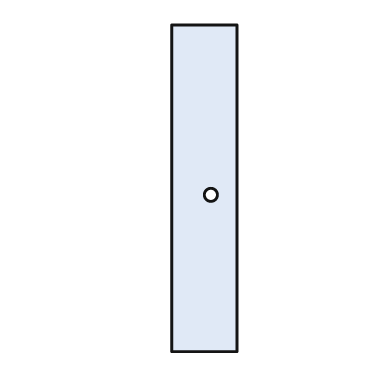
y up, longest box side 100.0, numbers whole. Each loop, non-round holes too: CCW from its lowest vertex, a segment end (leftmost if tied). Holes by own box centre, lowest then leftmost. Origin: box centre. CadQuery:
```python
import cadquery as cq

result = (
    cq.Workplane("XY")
    .moveTo(-10.0, -50.0)
    .lineTo(10.0, -50.0)
    .lineTo(10.0, 50.0)
    .lineTo(-10.0, 50.0)
    .close()
    .moveTo(2.0, -2.0)
    .circle(2.0)
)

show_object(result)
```